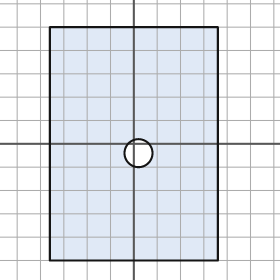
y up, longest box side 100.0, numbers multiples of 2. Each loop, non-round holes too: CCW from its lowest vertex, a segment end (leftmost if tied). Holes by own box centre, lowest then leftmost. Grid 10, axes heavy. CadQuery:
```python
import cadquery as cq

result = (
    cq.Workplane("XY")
    .moveTo(-36.0, -50.0)
    .lineTo(36.0, -50.0)
    .lineTo(36.0, 50.0)
    .lineTo(-36.0, 50.0)
    .close()
    .moveTo(2.0, -4.0)
    .circle(6.0)
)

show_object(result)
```